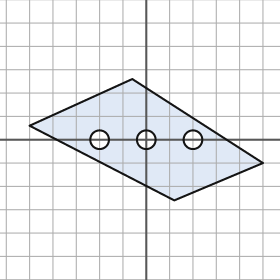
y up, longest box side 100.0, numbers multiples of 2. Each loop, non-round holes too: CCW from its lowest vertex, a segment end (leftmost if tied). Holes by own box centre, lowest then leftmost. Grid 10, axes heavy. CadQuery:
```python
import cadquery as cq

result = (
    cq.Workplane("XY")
    .moveTo(12.0, -26.0)
    .lineTo(50.0, -10.0)
    .lineTo(-6.0, 26.0)
    .lineTo(-50.0, 6.0)
    .close()
    .moveTo(-20.0, 0.0)
    .circle(4.0)
    .moveTo(0.0, 0.0)
    .circle(4.0)
    .moveTo(20.0, 0.0)
    .circle(4.0)
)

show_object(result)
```